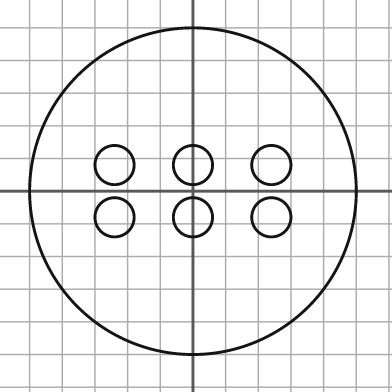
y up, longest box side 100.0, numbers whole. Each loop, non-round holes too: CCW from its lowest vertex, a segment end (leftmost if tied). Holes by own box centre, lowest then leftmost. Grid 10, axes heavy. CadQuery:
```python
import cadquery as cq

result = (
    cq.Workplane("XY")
    .moveTo(0.0, 0.0)
    .circle(50.0)
    .moveTo(-24.0, -8.0)
    .circle(6.0)
    .moveTo(0.0, -8.0)
    .circle(6.0)
    .moveTo(24.0, -8.0)
    .circle(6.0)
    .moveTo(-24.0, 8.0)
    .circle(6.0)
    .moveTo(0.0, 8.0)
    .circle(6.0)
    .moveTo(24.0, 8.0)
    .circle(6.0)
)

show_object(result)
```